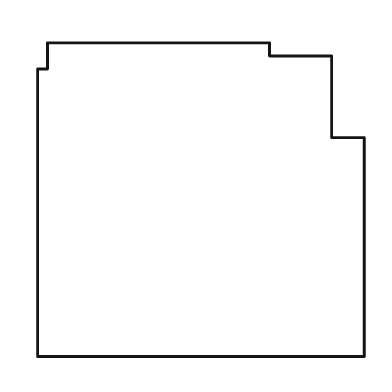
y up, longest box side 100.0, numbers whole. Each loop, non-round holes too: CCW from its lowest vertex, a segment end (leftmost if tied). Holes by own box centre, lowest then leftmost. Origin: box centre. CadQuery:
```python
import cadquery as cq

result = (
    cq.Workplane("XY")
    .moveTo(-50.0, -48.0)
    .lineTo(50.0, -48.0)
    .lineTo(50.0, 19.0)
    .lineTo(40.0, 19.0)
    .lineTo(40.0, 44.0)
    .lineTo(21.0, 44.0)
    .lineTo(21.0, 48.0)
    .lineTo(-47.0, 48.0)
    .lineTo(-47.0, 40.0)
    .lineTo(-50.0, 40.0)
    .close()
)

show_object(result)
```